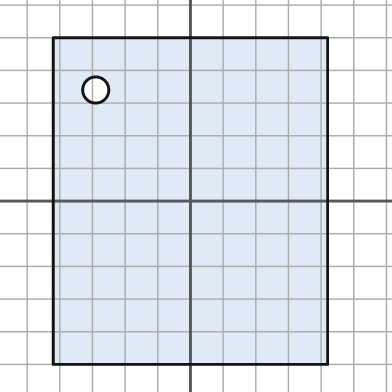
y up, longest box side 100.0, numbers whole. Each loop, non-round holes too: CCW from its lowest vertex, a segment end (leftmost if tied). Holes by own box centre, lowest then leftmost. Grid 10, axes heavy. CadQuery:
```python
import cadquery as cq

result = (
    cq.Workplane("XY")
    .moveTo(-42.0, -50.0)
    .lineTo(42.0, -50.0)
    .lineTo(42.0, 50.0)
    .lineTo(-42.0, 50.0)
    .close()
    .moveTo(-29.0, 34.0)
    .circle(4.0)
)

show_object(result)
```